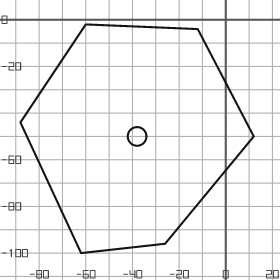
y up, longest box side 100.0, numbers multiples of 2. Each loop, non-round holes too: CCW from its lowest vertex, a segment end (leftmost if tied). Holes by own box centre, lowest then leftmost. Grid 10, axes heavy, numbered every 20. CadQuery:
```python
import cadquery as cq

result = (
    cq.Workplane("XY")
    .moveTo(-62.0, -100.0)
    .lineTo(-26.0, -96.0)
    .lineTo(12.0, -50.0)
    .lineTo(-12.0, -4.0)
    .lineTo(-60.0, -2.0)
    .lineTo(-88.0, -44.0)
    .close()
    .moveTo(-38.0, -50.0)
    .circle(4.0)
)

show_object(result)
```